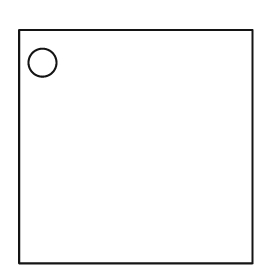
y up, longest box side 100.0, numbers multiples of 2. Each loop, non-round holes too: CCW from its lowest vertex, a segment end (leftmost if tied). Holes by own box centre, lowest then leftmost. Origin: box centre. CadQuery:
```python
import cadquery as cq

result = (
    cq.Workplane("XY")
    .moveTo(-50.0, -50.0)
    .lineTo(50.0, -50.0)
    .lineTo(50.0, 50.0)
    .lineTo(-50.0, 50.0)
    .close()
    .moveTo(-40.0, 36.0)
    .circle(6.0)
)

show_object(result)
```